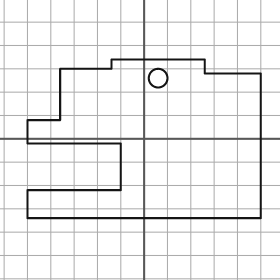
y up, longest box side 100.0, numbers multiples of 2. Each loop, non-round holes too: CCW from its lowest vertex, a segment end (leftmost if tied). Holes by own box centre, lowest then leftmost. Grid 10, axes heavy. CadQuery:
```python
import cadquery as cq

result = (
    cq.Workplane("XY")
    .moveTo(-50.0, -34.0)
    .lineTo(50.0, -34.0)
    .lineTo(50.0, 28.0)
    .lineTo(26.0, 28.0)
    .lineTo(26.0, 34.0)
    .lineTo(-14.0, 34.0)
    .lineTo(-14.0, 30.0)
    .lineTo(-36.0, 30.0)
    .lineTo(-36.0, 8.0)
    .lineTo(-50.0, 8.0)
    .lineTo(-50.0, -2.0)
    .lineTo(-10.0, -2.0)
    .lineTo(-10.0, -22.0)
    .lineTo(-50.0, -22.0)
    .close()
    .moveTo(6.0, 26.0)
    .circle(4.0)
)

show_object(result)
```